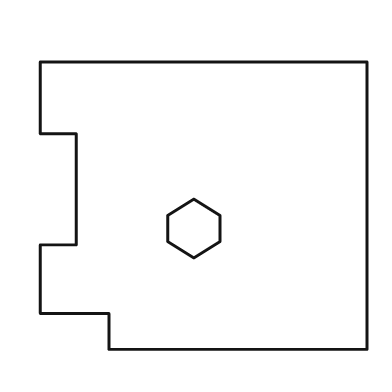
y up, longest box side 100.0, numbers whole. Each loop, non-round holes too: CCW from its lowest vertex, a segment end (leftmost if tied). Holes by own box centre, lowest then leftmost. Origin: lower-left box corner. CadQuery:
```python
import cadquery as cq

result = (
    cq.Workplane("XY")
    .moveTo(21.0, 0.0)
    .lineTo(100.0, 0.0)
    .lineTo(100.0, 88.0)
    .lineTo(0.0, 88.0)
    .lineTo(0.0, 66.0)
    .lineTo(11.0, 66.0)
    .lineTo(11.0, 32.0)
    .lineTo(0.0, 32.0)
    .lineTo(0.0, 11.0)
    .lineTo(21.0, 11.0)
    .close()
    .moveTo(47.0, 28.0)
    .lineTo(55.0, 33.0)
    .lineTo(55.0, 41.0)
    .lineTo(47.0, 46.0)
    .lineTo(39.0, 41.0)
    .lineTo(39.0, 33.0)
    .close()
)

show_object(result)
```